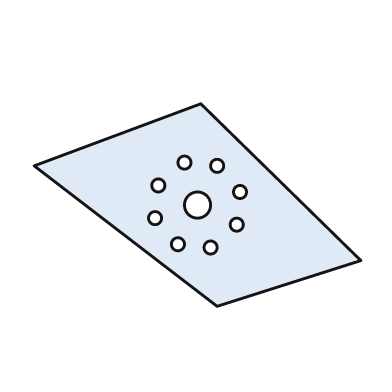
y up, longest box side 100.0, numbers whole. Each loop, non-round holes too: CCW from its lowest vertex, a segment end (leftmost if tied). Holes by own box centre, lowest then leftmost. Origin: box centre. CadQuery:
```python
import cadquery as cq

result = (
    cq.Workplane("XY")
    .moveTo(6.0, -31.0)
    .lineTo(50.0, -17.0)
    .lineTo(1.0, 31.0)
    .lineTo(-50.0, 12.0)
    .close()
    .moveTo(4.0, -13.0)
    .circle(2.0)
    .moveTo(-6.0, -12.0)
    .circle(2.0)
    .moveTo(12.0, -6.0)
    .circle(2.0)
    .moveTo(-13.0, -4.0)
    .circle(2.0)
    .moveTo(0.0, 0.0)
    .circle(4.0)
    .moveTo(13.0, 4.0)
    .circle(2.0)
    .moveTo(-12.0, 6.0)
    .circle(2.0)
    .moveTo(6.0, 12.0)
    .circle(2.0)
    .moveTo(-4.0, 13.0)
    .circle(2.0)
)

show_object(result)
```